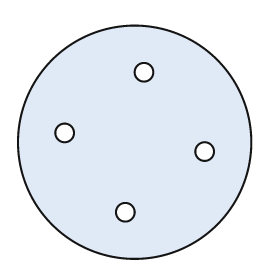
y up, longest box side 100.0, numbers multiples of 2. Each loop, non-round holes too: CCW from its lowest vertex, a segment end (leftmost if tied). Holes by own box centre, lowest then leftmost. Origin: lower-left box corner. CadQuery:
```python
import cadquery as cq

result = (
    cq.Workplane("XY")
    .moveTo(50.0, 50.0)
    .circle(50.0)
    .moveTo(46.0, 20.0)
    .circle(4.0)
    .moveTo(80.0, 46.0)
    .circle(4.0)
    .moveTo(20.0, 54.0)
    .circle(4.0)
    .moveTo(54.0, 80.0)
    .circle(4.0)
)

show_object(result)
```